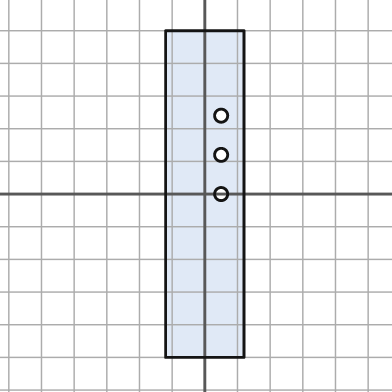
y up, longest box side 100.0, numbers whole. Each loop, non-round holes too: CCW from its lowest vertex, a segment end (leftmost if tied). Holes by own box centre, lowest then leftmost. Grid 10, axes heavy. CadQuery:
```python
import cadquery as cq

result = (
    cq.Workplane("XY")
    .moveTo(-12.0, -50.0)
    .lineTo(12.0, -50.0)
    .lineTo(12.0, 50.0)
    .lineTo(-12.0, 50.0)
    .close()
    .moveTo(5.0, 0.0)
    .circle(2.0)
    .moveTo(5.0, 12.0)
    .circle(2.0)
    .moveTo(5.0, 24.0)
    .circle(2.0)
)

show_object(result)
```